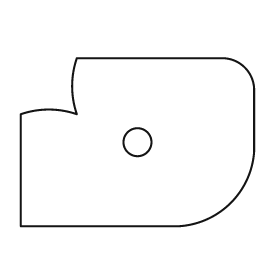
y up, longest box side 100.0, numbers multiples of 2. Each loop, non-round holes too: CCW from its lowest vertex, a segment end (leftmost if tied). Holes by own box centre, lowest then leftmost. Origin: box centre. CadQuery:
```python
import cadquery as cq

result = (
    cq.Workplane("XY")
    .moveTo(-50.0, -36.0)
    .lineTo(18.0, -36.0)
    .threePointArc((40.0, -26.0), (50.0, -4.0))
    .lineTo(50.0, 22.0)
    .threePointArc((46.0, 32.0), (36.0, 36.0))
    .lineTo(-26.0, 36.0)
    .threePointArc((-28.0, 24.0), (-26.0, 12.0))
    .threePointArc((-38.0, 14.0), (-50.0, 12.0))
    .close()
    .moveTo(0.0, 0.0)
    .circle(6.0)
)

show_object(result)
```